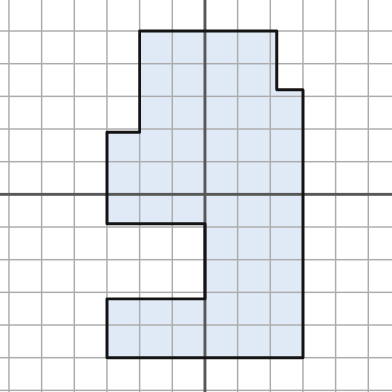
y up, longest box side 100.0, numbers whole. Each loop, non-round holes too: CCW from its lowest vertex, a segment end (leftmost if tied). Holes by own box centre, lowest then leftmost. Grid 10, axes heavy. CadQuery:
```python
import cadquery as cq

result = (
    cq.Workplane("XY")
    .moveTo(-30.0, -50.0)
    .lineTo(30.0, -50.0)
    .lineTo(30.0, 32.0)
    .lineTo(22.0, 32.0)
    .lineTo(22.0, 50.0)
    .lineTo(-20.0, 50.0)
    .lineTo(-20.0, 19.0)
    .lineTo(-30.0, 19.0)
    .lineTo(-30.0, -9.0)
    .lineTo(0.0, -9.0)
    .lineTo(0.0, -32.0)
    .lineTo(-30.0, -32.0)
    .close()
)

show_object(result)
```